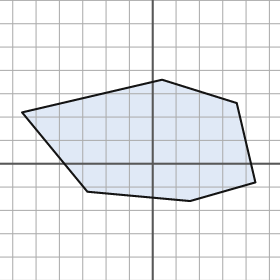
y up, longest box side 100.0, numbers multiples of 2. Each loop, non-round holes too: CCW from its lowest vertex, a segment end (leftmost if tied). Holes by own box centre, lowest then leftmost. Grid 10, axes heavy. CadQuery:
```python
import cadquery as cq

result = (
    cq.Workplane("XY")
    .moveTo(16.0, -16.0)
    .lineTo(44.0, -8.0)
    .lineTo(36.0, 26.0)
    .lineTo(4.0, 36.0)
    .lineTo(-56.0, 22.0)
    .lineTo(-28.0, -12.0)
    .close()
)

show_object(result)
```